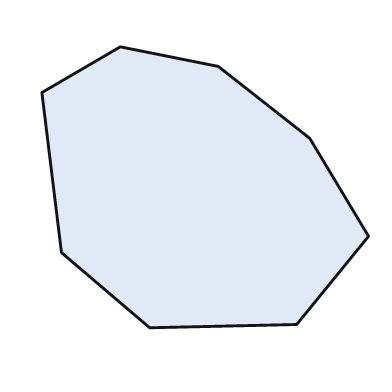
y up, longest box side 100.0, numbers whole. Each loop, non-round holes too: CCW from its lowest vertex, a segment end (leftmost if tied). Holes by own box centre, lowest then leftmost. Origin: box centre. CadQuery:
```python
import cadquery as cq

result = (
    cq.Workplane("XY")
    .moveTo(-17.0, -43.0)
    .lineTo(28.0, -42.0)
    .lineTo(50.0, -15.0)
    .lineTo(32.0, 15.0)
    .lineTo(4.0, 37.0)
    .lineTo(-26.0, 43.0)
    .lineTo(-50.0, 29.0)
    .lineTo(-44.0, -20.0)
    .close()
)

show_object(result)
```